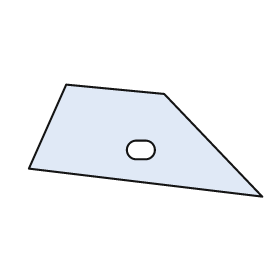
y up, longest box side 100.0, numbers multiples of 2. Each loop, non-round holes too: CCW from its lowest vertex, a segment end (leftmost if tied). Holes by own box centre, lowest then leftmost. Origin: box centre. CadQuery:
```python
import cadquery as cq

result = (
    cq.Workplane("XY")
    .moveTo(50.0, -24.0)
    .lineTo(8.0, 20.0)
    .lineTo(-34.0, 24.0)
    .lineTo(-50.0, -12.0)
    .close()
    .moveTo(-4.0, -8.0)
    .lineTo(0.0, -8.0)
    .threePointArc((4.0, -4.0), (0.0, 0.0))
    .lineTo(-4.0, 0.0)
    .threePointArc((-8.0, -4.0), (-4.0, -8.0))
    .close()
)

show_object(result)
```